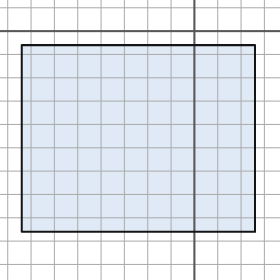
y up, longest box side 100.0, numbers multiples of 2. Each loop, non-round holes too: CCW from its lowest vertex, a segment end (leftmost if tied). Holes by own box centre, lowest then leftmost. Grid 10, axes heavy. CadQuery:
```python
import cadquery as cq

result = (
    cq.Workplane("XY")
    .moveTo(-74.0, -86.0)
    .lineTo(26.0, -86.0)
    .lineTo(26.0, -6.0)
    .lineTo(-74.0, -6.0)
    .close()
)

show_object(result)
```